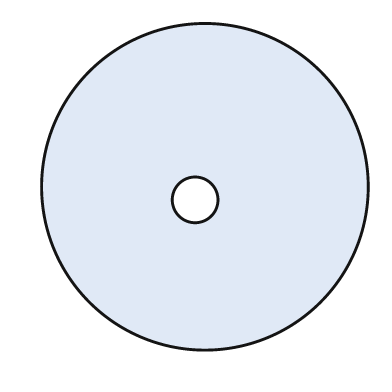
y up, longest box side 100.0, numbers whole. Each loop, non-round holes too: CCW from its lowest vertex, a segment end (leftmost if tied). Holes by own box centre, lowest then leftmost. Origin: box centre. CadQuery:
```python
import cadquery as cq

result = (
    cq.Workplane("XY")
    .moveTo(0.0, 0.0)
    .circle(50.0)
    .moveTo(-3.0, -4.0)
    .circle(7.0)
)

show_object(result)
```